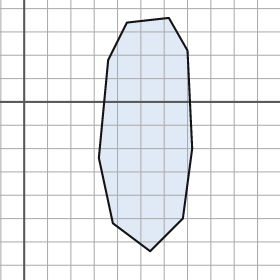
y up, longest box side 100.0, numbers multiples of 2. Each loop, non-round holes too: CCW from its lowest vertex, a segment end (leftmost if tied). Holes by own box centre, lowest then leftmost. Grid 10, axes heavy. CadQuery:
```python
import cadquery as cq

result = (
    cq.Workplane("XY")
    .moveTo(54.0, -64.0)
    .lineTo(68.0, -50.0)
    .lineTo(72.0, -20.0)
    .lineTo(70.0, 22.0)
    .lineTo(62.0, 36.0)
    .lineTo(44.0, 34.0)
    .lineTo(36.0, 18.0)
    .lineTo(32.0, -24.0)
    .lineTo(38.0, -52.0)
    .close()
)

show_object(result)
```